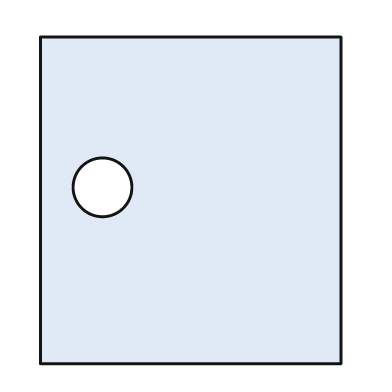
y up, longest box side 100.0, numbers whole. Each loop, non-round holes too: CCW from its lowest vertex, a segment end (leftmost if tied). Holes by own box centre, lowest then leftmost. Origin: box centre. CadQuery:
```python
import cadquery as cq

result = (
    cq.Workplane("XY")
    .moveTo(-46.0, -50.0)
    .lineTo(46.0, -50.0)
    .lineTo(46.0, 50.0)
    .lineTo(-46.0, 50.0)
    .close()
    .moveTo(-27.0, 4.0)
    .circle(9.0)
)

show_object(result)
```